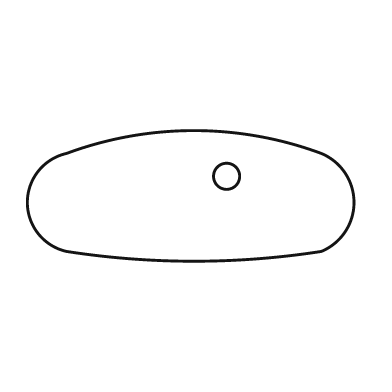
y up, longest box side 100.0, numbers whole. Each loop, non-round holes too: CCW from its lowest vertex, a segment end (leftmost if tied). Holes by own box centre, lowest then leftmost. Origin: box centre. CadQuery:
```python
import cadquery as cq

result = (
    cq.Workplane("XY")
    .moveTo(-38.0, -17.0)
    .threePointArc((1.0, -20.0), (40.0, -17.0))
    .threePointArc((50.0, -2.0), (40.0, 13.0))
    .threePointArc((1.0, 20.0), (-38.0, 13.0))
    .threePointArc((-50.0, -2.0), (-38.0, -17.0))
    .close()
    .moveTo(11.0, 6.0)
    .circle(4.0)
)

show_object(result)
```